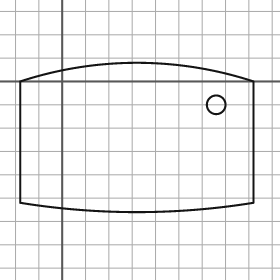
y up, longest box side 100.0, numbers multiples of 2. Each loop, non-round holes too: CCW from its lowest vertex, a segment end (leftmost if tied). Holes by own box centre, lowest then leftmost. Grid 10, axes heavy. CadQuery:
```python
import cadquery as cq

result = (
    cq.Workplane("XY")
    .moveTo(-18.0, -52.0)
    .threePointArc((32.0, -56.0), (82.0, -52.0))
    .lineTo(82.0, 0.0)
    .threePointArc((32.0, 8.0), (-18.0, 0.0))
    .close()
    .moveTo(66.0, -10.0)
    .circle(4.0)
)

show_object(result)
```